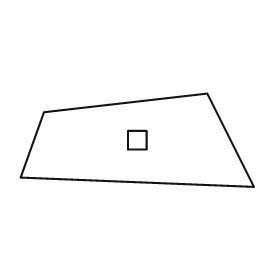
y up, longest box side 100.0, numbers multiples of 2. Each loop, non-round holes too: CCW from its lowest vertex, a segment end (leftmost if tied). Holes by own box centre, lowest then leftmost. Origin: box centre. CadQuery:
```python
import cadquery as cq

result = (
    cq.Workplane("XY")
    .moveTo(50.0, -20.0)
    .lineTo(30.0, 20.0)
    .lineTo(-40.0, 12.0)
    .lineTo(-50.0, -16.0)
    .close()
    .moveTo(-4.0, -4.0)
    .lineTo(4.0, -4.0)
    .lineTo(4.0, 4.0)
    .lineTo(-4.0, 4.0)
    .close()
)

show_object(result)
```